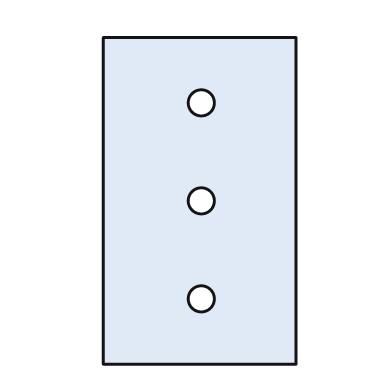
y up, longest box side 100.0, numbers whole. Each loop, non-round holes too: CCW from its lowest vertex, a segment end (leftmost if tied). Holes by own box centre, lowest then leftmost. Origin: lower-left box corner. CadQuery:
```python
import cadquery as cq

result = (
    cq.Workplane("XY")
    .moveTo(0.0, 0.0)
    .lineTo(59.0, 0.0)
    .lineTo(59.0, 100.0)
    .lineTo(0.0, 100.0)
    .close()
    .moveTo(30.0, 20.0)
    .circle(4.0)
    .moveTo(30.0, 50.0)
    .circle(4.0)
    .moveTo(30.0, 80.0)
    .circle(4.0)
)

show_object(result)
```